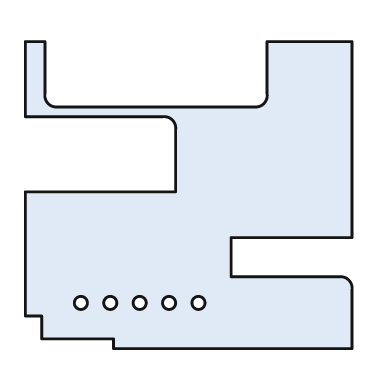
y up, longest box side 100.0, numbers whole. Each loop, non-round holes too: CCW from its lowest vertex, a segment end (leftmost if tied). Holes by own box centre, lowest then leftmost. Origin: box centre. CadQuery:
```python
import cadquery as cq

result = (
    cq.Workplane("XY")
    .moveTo(-23.0, -47.0)
    .lineTo(50.0, -47.0)
    .lineTo(50.0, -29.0)
    .threePointArc((49.0, -26.0), (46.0, -25.0))
    .lineTo(13.0, -25.0)
    .lineTo(13.0, -13.0)
    .lineTo(50.0, -13.0)
    .lineTo(50.0, 47.0)
    .lineTo(24.0, 47.0)
    .lineTo(24.0, 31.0)
    .threePointArc((23.0, 28.0), (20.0, 27.0))
    .lineTo(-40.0, 27.0)
    .threePointArc((-43.0, 28.0), (-44.0, 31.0))
    .lineTo(-44.0, 47.0)
    .lineTo(-50.0, 47.0)
    .lineTo(-50.0, 24.0)
    .lineTo(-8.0, 24.0)
    .threePointArc((-5.0, 23.0), (-4.0, 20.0))
    .lineTo(-4.0, 1.0)
    .lineTo(-50.0, 1.0)
    .lineTo(-50.0, -37.0)
    .lineTo(-45.0, -37.0)
    .lineTo(-45.0, -44.0)
    .lineTo(-23.0, -44.0)
    .close()
    .moveTo(-33.0, -33.0)
    .circle(2.0)
    .moveTo(-24.0, -33.0)
    .circle(2.0)
    .moveTo(-15.0, -33.0)
    .circle(2.0)
    .moveTo(-6.0, -33.0)
    .circle(2.0)
    .moveTo(3.0, -33.0)
    .circle(2.0)
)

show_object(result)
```